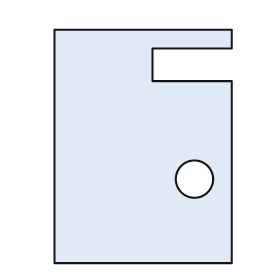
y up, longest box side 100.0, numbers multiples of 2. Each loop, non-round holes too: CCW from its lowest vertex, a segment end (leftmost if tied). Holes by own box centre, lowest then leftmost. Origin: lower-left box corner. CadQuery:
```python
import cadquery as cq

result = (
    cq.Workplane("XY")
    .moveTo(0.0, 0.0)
    .lineTo(76.0, 0.0)
    .lineTo(76.0, 78.0)
    .lineTo(42.0, 78.0)
    .lineTo(42.0, 92.0)
    .lineTo(76.0, 92.0)
    .lineTo(76.0, 100.0)
    .lineTo(0.0, 100.0)
    .close()
    .moveTo(60.0, 36.0)
    .circle(8.0)
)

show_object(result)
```